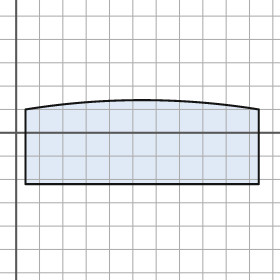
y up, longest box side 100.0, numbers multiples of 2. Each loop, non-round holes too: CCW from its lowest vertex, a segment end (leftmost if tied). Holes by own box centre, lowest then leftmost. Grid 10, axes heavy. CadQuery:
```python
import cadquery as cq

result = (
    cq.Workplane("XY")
    .moveTo(4.0, -22.0)
    .lineTo(104.0, -22.0)
    .lineTo(104.0, 10.0)
    .threePointArc((54.0, 14.0), (4.0, 10.0))
    .close()
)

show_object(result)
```